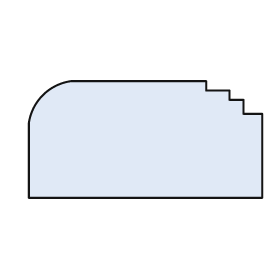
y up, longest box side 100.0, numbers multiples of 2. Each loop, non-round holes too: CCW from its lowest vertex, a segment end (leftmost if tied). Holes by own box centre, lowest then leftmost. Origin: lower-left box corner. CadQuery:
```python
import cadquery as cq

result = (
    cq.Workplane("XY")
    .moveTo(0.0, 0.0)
    .lineTo(100.0, 0.0)
    .lineTo(100.0, 36.0)
    .lineTo(92.0, 36.0)
    .lineTo(92.0, 42.0)
    .lineTo(86.0, 42.0)
    .lineTo(86.0, 46.0)
    .lineTo(76.0, 46.0)
    .lineTo(76.0, 50.0)
    .lineTo(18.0, 50.0)
    .threePointArc((6.0, 44.0), (0.0, 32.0))
    .close()
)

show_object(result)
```